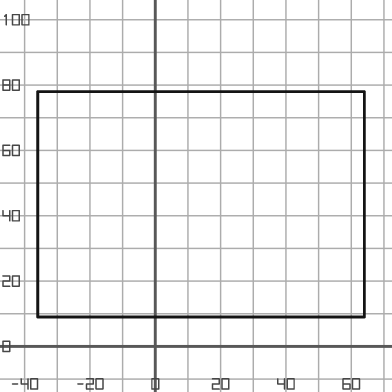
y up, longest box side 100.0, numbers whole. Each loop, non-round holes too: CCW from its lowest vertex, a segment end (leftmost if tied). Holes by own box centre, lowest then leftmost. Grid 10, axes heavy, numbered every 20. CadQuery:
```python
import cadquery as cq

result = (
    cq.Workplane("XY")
    .moveTo(-36.0, 9.0)
    .lineTo(64.0, 9.0)
    .lineTo(64.0, 78.0)
    .lineTo(-36.0, 78.0)
    .close()
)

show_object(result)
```